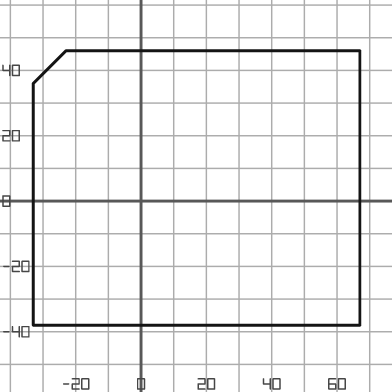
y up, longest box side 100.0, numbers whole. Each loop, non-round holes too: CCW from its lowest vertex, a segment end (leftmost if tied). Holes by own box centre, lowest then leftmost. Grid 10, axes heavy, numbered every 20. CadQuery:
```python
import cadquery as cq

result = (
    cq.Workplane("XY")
    .moveTo(-33.0, -38.0)
    .lineTo(67.0, -38.0)
    .lineTo(67.0, 46.0)
    .lineTo(-23.0, 46.0)
    .lineTo(-33.0, 36.0)
    .close()
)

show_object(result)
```